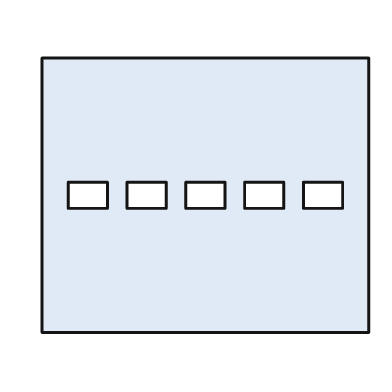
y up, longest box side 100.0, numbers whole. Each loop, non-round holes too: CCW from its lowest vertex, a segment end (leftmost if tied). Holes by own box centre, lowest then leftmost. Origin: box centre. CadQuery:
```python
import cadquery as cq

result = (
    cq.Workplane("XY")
    .moveTo(-50.0, -42.0)
    .lineTo(50.0, -42.0)
    .lineTo(50.0, 42.0)
    .lineTo(-50.0, 42.0)
    .close()
    .moveTo(-42.0, -4.0)
    .lineTo(-30.0, -4.0)
    .lineTo(-30.0, 4.0)
    .lineTo(-42.0, 4.0)
    .close()
    .moveTo(-24.0, -4.0)
    .lineTo(-12.0, -4.0)
    .lineTo(-12.0, 4.0)
    .lineTo(-24.0, 4.0)
    .close()
    .moveTo(-6.0, -4.0)
    .lineTo(6.0, -4.0)
    .lineTo(6.0, 4.0)
    .lineTo(-6.0, 4.0)
    .close()
    .moveTo(12.0, -4.0)
    .lineTo(24.0, -4.0)
    .lineTo(24.0, 4.0)
    .lineTo(12.0, 4.0)
    .close()
    .moveTo(30.0, -4.0)
    .lineTo(42.0, -4.0)
    .lineTo(42.0, 4.0)
    .lineTo(30.0, 4.0)
    .close()
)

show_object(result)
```